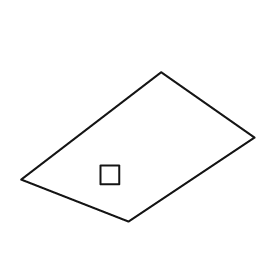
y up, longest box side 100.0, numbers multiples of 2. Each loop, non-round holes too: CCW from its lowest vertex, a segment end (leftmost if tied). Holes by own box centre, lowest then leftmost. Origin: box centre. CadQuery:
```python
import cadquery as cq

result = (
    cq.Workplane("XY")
    .moveTo(-4.0, -32.0)
    .lineTo(50.0, 4.0)
    .lineTo(10.0, 32.0)
    .lineTo(-50.0, -14.0)
    .close()
    .moveTo(-16.0, -16.0)
    .lineTo(-8.0, -16.0)
    .lineTo(-8.0, -8.0)
    .lineTo(-16.0, -8.0)
    .close()
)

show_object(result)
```